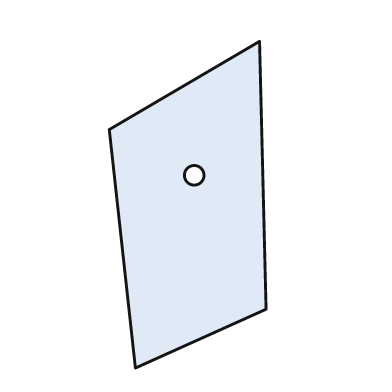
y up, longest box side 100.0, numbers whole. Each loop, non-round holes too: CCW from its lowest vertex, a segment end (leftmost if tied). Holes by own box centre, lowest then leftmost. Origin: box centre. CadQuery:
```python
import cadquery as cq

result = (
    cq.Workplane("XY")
    .moveTo(-16.0, -50.0)
    .lineTo(24.0, -32.0)
    .lineTo(22.0, 50.0)
    .lineTo(-24.0, 23.0)
    .close()
    .moveTo(2.0, 9.0)
    .circle(3.0)
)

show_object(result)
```